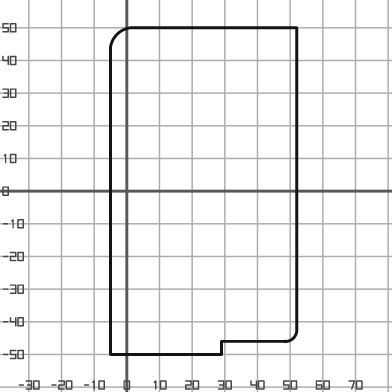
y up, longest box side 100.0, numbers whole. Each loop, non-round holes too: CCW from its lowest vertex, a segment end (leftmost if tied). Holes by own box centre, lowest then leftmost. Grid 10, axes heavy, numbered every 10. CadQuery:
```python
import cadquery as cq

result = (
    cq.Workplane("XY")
    .moveTo(-5.0, -50.0)
    .lineTo(29.0, -50.0)
    .lineTo(29.0, -46.0)
    .lineTo(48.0, -46.0)
    .threePointArc((51.0, -45.0), (52.0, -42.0))
    .lineTo(52.0, 50.0)
    .lineTo(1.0, 50.0)
    .threePointArc((-3.0, 48.0), (-5.0, 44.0))
    .close()
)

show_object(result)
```